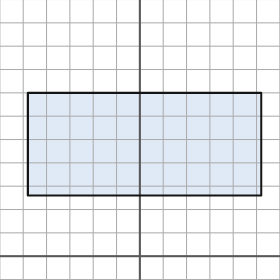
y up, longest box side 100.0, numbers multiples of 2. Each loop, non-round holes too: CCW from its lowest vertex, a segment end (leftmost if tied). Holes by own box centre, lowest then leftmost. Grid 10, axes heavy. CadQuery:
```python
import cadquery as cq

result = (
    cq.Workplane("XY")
    .moveTo(-48.0, 26.0)
    .lineTo(52.0, 26.0)
    .lineTo(52.0, 70.0)
    .lineTo(-48.0, 70.0)
    .close()
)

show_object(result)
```